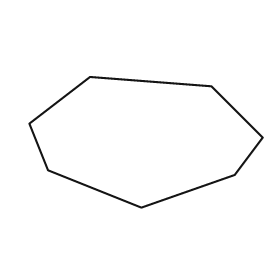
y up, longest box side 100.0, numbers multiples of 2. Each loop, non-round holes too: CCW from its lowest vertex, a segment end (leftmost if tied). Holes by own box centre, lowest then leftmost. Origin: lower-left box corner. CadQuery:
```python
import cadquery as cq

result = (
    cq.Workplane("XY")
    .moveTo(48.0, 0.0)
    .lineTo(88.0, 14.0)
    .lineTo(100.0, 30.0)
    .lineTo(78.0, 52.0)
    .lineTo(26.0, 56.0)
    .lineTo(0.0, 36.0)
    .lineTo(8.0, 16.0)
    .close()
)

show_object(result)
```